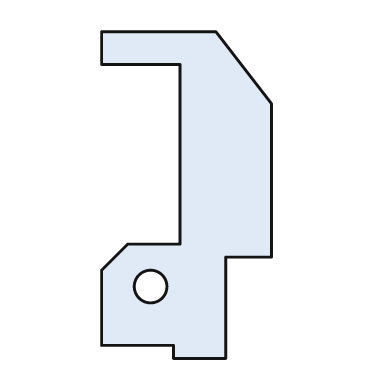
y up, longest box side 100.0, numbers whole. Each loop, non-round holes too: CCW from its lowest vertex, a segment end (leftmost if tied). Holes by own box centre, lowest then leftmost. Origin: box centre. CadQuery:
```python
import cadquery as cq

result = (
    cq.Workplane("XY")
    .moveTo(-4.0, -50.0)
    .lineTo(12.0, -50.0)
    .lineTo(12.0, -19.0)
    .lineTo(26.0, -19.0)
    .lineTo(26.0, 28.0)
    .lineTo(9.0, 50.0)
    .lineTo(-26.0, 50.0)
    .lineTo(-26.0, 40.0)
    .lineTo(-2.0, 40.0)
    .lineTo(-2.0, -15.0)
    .lineTo(-18.0, -15.0)
    .lineTo(-26.0, -23.0)
    .lineTo(-26.0, -46.0)
    .lineTo(-4.0, -46.0)
    .close()
    .moveTo(-11.0, -28.0)
    .circle(5.0)
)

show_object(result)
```